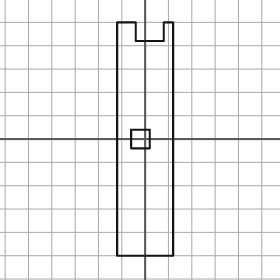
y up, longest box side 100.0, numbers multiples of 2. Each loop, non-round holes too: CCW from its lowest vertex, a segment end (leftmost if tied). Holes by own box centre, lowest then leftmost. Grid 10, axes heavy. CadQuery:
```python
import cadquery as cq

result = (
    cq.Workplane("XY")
    .moveTo(-12.0, -50.0)
    .lineTo(12.0, -50.0)
    .lineTo(12.0, 50.0)
    .lineTo(8.0, 50.0)
    .lineTo(8.0, 42.0)
    .lineTo(-4.0, 42.0)
    .lineTo(-4.0, 50.0)
    .lineTo(-12.0, 50.0)
    .close()
    .moveTo(-6.0, -4.0)
    .lineTo(2.0, -4.0)
    .lineTo(2.0, 4.0)
    .lineTo(-6.0, 4.0)
    .close()
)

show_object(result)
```